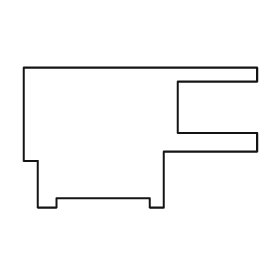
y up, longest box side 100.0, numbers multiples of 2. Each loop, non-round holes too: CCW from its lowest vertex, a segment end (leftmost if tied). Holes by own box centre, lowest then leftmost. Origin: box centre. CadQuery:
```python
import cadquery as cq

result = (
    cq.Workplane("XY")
    .moveTo(-44.0, -30.0)
    .lineTo(-36.0, -30.0)
    .lineTo(-36.0, -26.0)
    .lineTo(4.0, -26.0)
    .lineTo(4.0, -30.0)
    .lineTo(10.0, -30.0)
    .lineTo(10.0, -6.0)
    .lineTo(50.0, -6.0)
    .lineTo(50.0, 2.0)
    .lineTo(16.0, 2.0)
    .lineTo(16.0, 24.0)
    .lineTo(50.0, 24.0)
    .lineTo(50.0, 30.0)
    .lineTo(-50.0, 30.0)
    .lineTo(-50.0, -10.0)
    .lineTo(-44.0, -10.0)
    .close()
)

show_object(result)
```